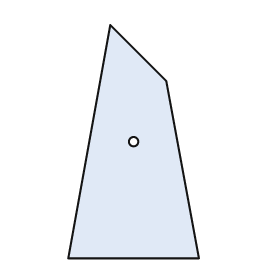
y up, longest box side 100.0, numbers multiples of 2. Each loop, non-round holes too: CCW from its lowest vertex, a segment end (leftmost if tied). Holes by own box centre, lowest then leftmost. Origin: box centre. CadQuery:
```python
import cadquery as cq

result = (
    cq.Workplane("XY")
    .moveTo(-28.0, -50.0)
    .lineTo(28.0, -50.0)
    .lineTo(14.0, 26.0)
    .lineTo(-10.0, 50.0)
    .close()
    .moveTo(0.0, 0.0)
    .circle(2.0)
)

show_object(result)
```